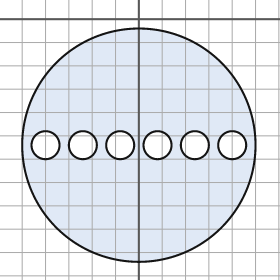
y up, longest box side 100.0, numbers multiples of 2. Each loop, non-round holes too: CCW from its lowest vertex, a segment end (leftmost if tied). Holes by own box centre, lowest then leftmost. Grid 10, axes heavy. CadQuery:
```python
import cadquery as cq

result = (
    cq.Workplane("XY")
    .moveTo(0.0, -54.0)
    .circle(50.0)
    .moveTo(-40.0, -54.0)
    .circle(6.0)
    .moveTo(-24.0, -54.0)
    .circle(6.0)
    .moveTo(-8.0, -54.0)
    .circle(6.0)
    .moveTo(8.0, -54.0)
    .circle(6.0)
    .moveTo(24.0, -54.0)
    .circle(6.0)
    .moveTo(40.0, -54.0)
    .circle(6.0)
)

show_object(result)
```